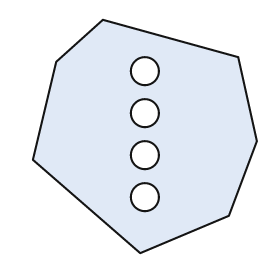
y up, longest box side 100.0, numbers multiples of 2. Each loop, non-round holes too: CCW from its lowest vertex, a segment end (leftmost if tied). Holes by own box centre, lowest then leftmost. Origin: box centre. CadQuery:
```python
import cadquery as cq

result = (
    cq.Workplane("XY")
    .moveTo(-2.0, -50.0)
    .lineTo(36.0, -34.0)
    .lineTo(48.0, -2.0)
    .lineTo(40.0, 34.0)
    .lineTo(-18.0, 50.0)
    .lineTo(-38.0, 32.0)
    .lineTo(-48.0, -10.0)
    .close()
    .moveTo(0.0, -26.0)
    .circle(6.0)
    .moveTo(0.0, -8.0)
    .circle(6.0)
    .moveTo(0.0, 10.0)
    .circle(6.0)
    .moveTo(0.0, 28.0)
    .circle(6.0)
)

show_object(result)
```